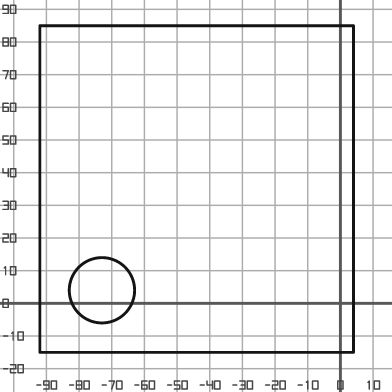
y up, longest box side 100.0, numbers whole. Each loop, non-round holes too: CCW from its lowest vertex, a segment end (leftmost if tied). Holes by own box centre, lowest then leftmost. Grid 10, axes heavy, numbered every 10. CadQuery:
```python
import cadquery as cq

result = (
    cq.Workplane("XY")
    .moveTo(-92.0, -15.0)
    .lineTo(4.0, -15.0)
    .lineTo(4.0, 85.0)
    .lineTo(-92.0, 85.0)
    .close()
    .moveTo(-73.0, 4.0)
    .circle(10.0)
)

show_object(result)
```